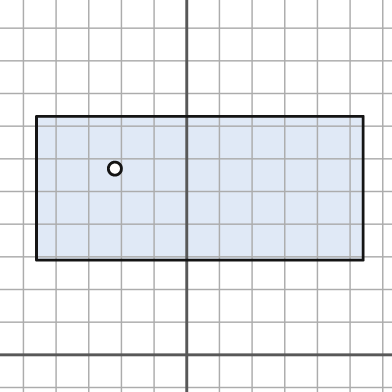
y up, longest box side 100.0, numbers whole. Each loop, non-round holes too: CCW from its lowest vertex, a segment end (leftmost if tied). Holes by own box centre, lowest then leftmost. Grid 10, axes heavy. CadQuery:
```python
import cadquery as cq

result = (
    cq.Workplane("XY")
    .moveTo(-46.0, 29.0)
    .lineTo(54.0, 29.0)
    .lineTo(54.0, 73.0)
    .lineTo(-46.0, 73.0)
    .close()
    .moveTo(-22.0, 57.0)
    .circle(2.0)
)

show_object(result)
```